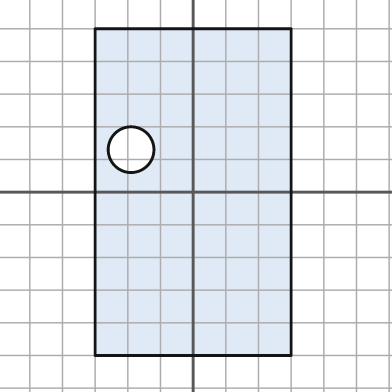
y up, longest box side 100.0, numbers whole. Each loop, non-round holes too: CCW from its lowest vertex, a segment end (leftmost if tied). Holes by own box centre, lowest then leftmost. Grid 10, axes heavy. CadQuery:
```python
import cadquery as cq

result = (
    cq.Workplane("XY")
    .moveTo(-30.0, -50.0)
    .lineTo(30.0, -50.0)
    .lineTo(30.0, 50.0)
    .lineTo(-30.0, 50.0)
    .close()
    .moveTo(-19.0, 13.0)
    .circle(7.0)
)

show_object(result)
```